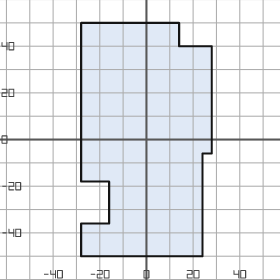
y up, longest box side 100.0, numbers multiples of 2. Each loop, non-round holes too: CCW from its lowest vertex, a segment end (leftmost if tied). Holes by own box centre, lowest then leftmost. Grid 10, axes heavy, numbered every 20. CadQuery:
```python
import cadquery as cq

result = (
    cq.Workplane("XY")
    .moveTo(-28.0, -50.0)
    .lineTo(24.0, -50.0)
    .lineTo(24.0, -6.0)
    .lineTo(28.0, -6.0)
    .lineTo(28.0, 40.0)
    .lineTo(14.0, 40.0)
    .lineTo(14.0, 50.0)
    .lineTo(-28.0, 50.0)
    .lineTo(-28.0, -18.0)
    .lineTo(-16.0, -18.0)
    .lineTo(-16.0, -36.0)
    .lineTo(-28.0, -36.0)
    .close()
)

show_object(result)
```